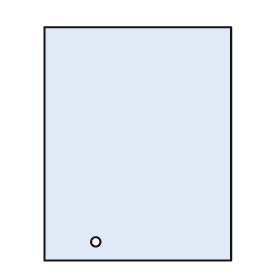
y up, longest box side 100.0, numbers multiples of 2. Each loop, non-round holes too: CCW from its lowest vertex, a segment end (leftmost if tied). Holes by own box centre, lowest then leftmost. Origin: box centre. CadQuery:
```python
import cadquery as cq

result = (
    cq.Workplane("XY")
    .moveTo(-40.0, -50.0)
    .lineTo(40.0, -50.0)
    .lineTo(40.0, 50.0)
    .lineTo(-40.0, 50.0)
    .close()
    .moveTo(-18.0, -42.0)
    .circle(2.0)
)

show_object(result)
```